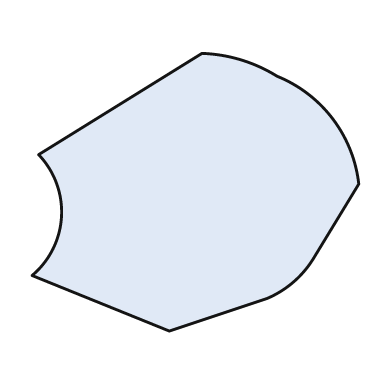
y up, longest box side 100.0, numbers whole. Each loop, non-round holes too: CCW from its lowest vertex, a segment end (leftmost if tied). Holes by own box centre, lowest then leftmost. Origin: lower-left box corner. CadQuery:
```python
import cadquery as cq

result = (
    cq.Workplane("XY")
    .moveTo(42.0, 0.0)
    .lineTo(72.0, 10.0)
    .threePointArc((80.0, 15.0), (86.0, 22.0))
    .lineTo(100.0, 45.0)
    .threePointArc((92.0, 65.0), (75.0, 78.0))
    .threePointArc((64.0, 83.0), (52.0, 85.0))
    .lineTo(2.0, 54.0)
    .threePointArc((9.0, 35.0), (0.0, 17.0))
    .close()
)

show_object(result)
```